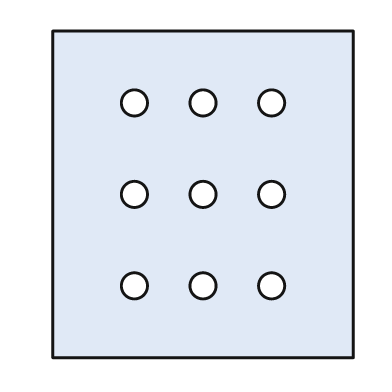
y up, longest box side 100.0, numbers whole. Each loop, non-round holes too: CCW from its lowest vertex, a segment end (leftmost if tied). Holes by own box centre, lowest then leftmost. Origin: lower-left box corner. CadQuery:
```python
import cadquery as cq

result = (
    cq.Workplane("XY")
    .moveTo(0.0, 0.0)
    .lineTo(92.0, 0.0)
    .lineTo(92.0, 100.0)
    .lineTo(0.0, 100.0)
    .close()
    .moveTo(25.0, 22.0)
    .circle(4.0)
    .moveTo(46.0, 22.0)
    .circle(4.0)
    .moveTo(67.0, 22.0)
    .circle(4.0)
    .moveTo(25.0, 50.0)
    .circle(4.0)
    .moveTo(46.0, 50.0)
    .circle(4.0)
    .moveTo(67.0, 50.0)
    .circle(4.0)
    .moveTo(25.0, 78.0)
    .circle(4.0)
    .moveTo(46.0, 78.0)
    .circle(4.0)
    .moveTo(67.0, 78.0)
    .circle(4.0)
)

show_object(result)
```